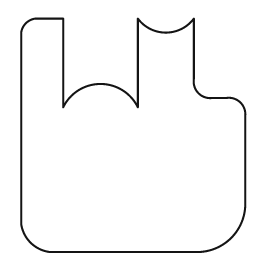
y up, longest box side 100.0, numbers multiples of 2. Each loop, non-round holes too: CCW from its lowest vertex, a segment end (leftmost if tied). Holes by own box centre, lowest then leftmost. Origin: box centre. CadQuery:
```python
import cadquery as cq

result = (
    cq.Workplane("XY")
    .moveTo(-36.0, -50.0)
    .lineTo(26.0, -50.0)
    .threePointArc((42.0, -44.0), (48.0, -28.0))
    .lineTo(48.0, 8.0)
    .threePointArc((46.0, 14.0), (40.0, 16.0))
    .lineTo(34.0, 16.0)
    .threePointArc((28.0, 18.0), (26.0, 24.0))
    .lineTo(26.0, 50.0)
    .threePointArc((14.0, 44.0), (2.0, 50.0))
    .lineTo(2.0, 12.0)
    .threePointArc((-14.0, 22.0), (-30.0, 12.0))
    .lineTo(-30.0, 50.0)
    .lineTo(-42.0, 50.0)
    .threePointArc((-46.0, 48.0), (-48.0, 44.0))
    .lineTo(-48.0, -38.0)
    .threePointArc((-44.0, -46.0), (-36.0, -50.0))
    .close()
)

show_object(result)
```